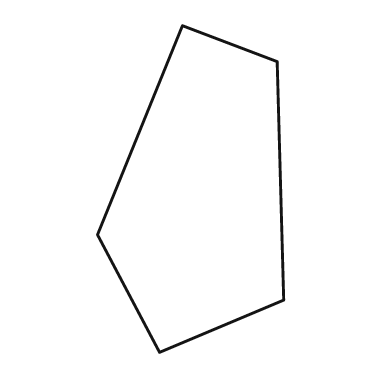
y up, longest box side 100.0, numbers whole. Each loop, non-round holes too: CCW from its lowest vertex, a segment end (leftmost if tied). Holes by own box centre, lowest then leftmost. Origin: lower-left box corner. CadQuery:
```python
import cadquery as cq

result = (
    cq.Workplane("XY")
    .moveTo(19.0, 0.0)
    .lineTo(57.0, 16.0)
    .lineTo(55.0, 89.0)
    .lineTo(26.0, 100.0)
    .lineTo(0.0, 36.0)
    .close()
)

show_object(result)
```